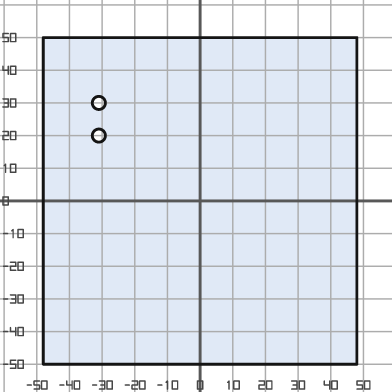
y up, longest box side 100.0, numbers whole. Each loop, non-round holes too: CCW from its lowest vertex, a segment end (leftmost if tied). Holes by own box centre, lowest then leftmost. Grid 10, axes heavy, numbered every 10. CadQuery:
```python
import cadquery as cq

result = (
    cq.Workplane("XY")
    .moveTo(-48.0, -50.0)
    .lineTo(48.0, -50.0)
    .lineTo(48.0, 50.0)
    .lineTo(-48.0, 50.0)
    .close()
    .moveTo(-31.0, 20.0)
    .circle(2.0)
    .moveTo(-31.0, 30.0)
    .circle(2.0)
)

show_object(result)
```